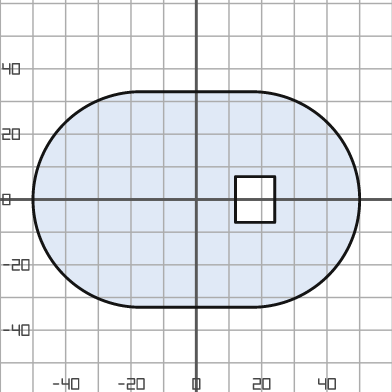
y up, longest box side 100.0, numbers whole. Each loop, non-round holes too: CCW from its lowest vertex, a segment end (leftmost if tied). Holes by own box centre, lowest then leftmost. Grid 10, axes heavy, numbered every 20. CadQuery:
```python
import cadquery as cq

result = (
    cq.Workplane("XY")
    .moveTo(-17.0, -33.0)
    .lineTo(17.0, -33.0)
    .threePointArc((50.0, 0.0), (17.0, 33.0))
    .lineTo(-17.0, 33.0)
    .threePointArc((-50.0, 0.0), (-17.0, -33.0))
    .close()
    .moveTo(12.0, -7.0)
    .lineTo(24.0, -7.0)
    .lineTo(24.0, 7.0)
    .lineTo(12.0, 7.0)
    .close()
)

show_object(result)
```